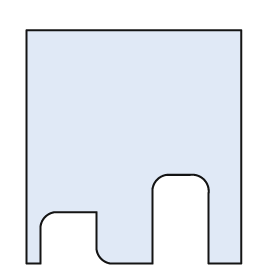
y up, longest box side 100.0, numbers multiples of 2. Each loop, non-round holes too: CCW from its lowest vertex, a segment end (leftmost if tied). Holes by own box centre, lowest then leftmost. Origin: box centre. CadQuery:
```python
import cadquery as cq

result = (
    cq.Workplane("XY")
    .moveTo(-46.0, -50.0)
    .lineTo(-40.0, -50.0)
    .lineTo(-40.0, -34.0)
    .threePointArc((-38.0, -30.0), (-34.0, -28.0))
    .lineTo(-16.0, -28.0)
    .lineTo(-16.0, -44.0)
    .threePointArc((-14.0, -48.0), (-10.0, -50.0))
    .lineTo(8.0, -50.0)
    .lineTo(8.0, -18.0)
    .threePointArc((10.0, -14.0), (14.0, -12.0))
    .lineTo(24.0, -12.0)
    .threePointArc((30.0, -14.0), (32.0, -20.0))
    .lineTo(32.0, -50.0)
    .lineTo(46.0, -50.0)
    .lineTo(46.0, 50.0)
    .lineTo(-46.0, 50.0)
    .close()
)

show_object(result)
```